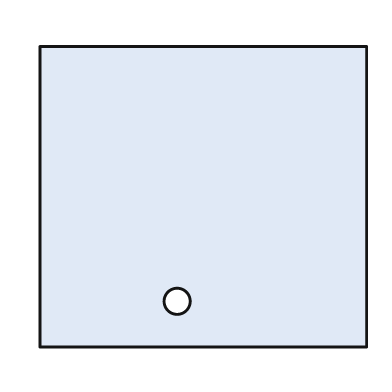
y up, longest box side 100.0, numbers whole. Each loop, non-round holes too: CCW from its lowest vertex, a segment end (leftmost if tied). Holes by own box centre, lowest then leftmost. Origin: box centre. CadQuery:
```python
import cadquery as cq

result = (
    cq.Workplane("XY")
    .moveTo(-50.0, -46.0)
    .lineTo(50.0, -46.0)
    .lineTo(50.0, 46.0)
    .lineTo(-50.0, 46.0)
    .close()
    .moveTo(-8.0, -32.0)
    .circle(4.0)
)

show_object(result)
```